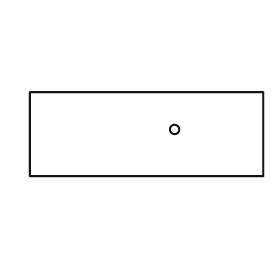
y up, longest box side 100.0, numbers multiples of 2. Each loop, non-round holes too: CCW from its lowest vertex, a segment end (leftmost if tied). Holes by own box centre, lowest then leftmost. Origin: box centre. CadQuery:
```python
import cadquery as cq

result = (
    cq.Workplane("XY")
    .moveTo(-50.0, -18.0)
    .lineTo(50.0, -18.0)
    .lineTo(50.0, 18.0)
    .lineTo(-50.0, 18.0)
    .close()
    .moveTo(12.0, 2.0)
    .circle(2.0)
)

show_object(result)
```